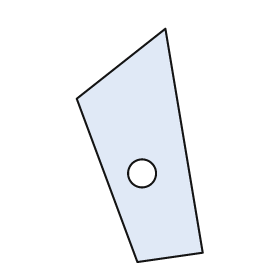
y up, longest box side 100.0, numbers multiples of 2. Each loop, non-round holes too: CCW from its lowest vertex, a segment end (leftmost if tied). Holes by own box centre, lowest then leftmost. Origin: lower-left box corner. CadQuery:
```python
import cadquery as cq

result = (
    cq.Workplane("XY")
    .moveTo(26.0, 0.0)
    .lineTo(54.0, 4.0)
    .lineTo(38.0, 100.0)
    .lineTo(0.0, 70.0)
    .close()
    .moveTo(28.0, 38.0)
    .circle(6.0)
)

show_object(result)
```